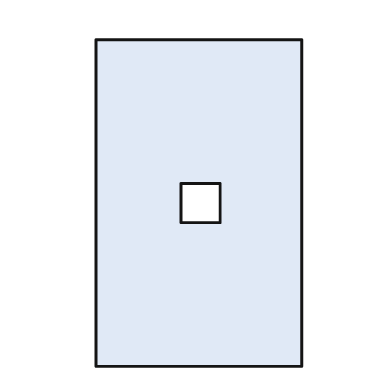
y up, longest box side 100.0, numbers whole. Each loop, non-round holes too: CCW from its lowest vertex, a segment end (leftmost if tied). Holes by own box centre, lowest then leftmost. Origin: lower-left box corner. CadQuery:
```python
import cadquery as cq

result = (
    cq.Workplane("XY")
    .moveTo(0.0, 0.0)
    .lineTo(63.0, 0.0)
    .lineTo(63.0, 100.0)
    .lineTo(0.0, 100.0)
    .close()
    .moveTo(26.0, 44.0)
    .lineTo(38.0, 44.0)
    .lineTo(38.0, 56.0)
    .lineTo(26.0, 56.0)
    .close()
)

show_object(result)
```